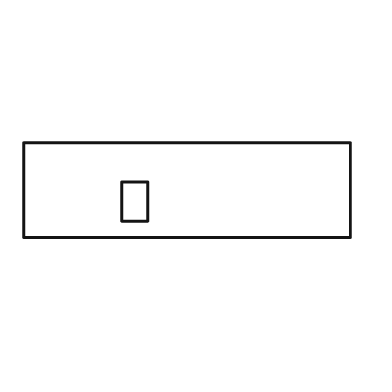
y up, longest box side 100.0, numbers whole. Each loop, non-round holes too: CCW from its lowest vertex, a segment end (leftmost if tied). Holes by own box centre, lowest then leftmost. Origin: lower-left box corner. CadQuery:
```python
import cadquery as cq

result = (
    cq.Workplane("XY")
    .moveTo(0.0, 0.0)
    .lineTo(100.0, 0.0)
    .lineTo(100.0, 29.0)
    .lineTo(0.0, 29.0)
    .close()
    .moveTo(30.0, 5.0)
    .lineTo(38.0, 5.0)
    .lineTo(38.0, 17.0)
    .lineTo(30.0, 17.0)
    .close()
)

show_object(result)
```